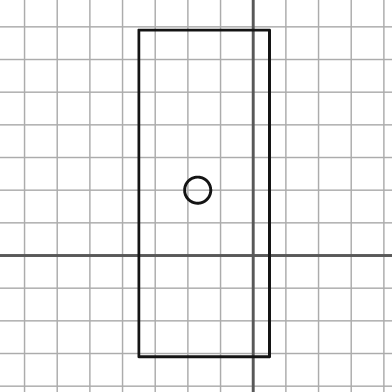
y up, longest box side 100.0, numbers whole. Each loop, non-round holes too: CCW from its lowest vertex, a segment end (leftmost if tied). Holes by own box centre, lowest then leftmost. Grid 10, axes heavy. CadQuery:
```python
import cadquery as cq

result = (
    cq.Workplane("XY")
    .moveTo(-35.0, -31.0)
    .lineTo(5.0, -31.0)
    .lineTo(5.0, 69.0)
    .lineTo(-35.0, 69.0)
    .close()
    .moveTo(-17.0, 20.0)
    .circle(4.0)
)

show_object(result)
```